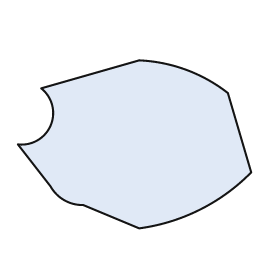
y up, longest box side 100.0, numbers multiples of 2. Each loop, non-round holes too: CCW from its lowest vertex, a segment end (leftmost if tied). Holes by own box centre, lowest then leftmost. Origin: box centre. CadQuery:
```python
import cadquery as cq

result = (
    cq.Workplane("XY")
    .moveTo(2.0, -36.0)
    .threePointArc((28.0, -28.0), (50.0, -12.0))
    .lineTo(40.0, 22.0)
    .threePointArc((22.0, 32.0), (2.0, 36.0))
    .lineTo(-40.0, 24.0)
    .threePointArc((-36.0, 8.0), (-50.0, 0.0))
    .lineTo(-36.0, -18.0)
    .threePointArc((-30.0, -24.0), (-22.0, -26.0))
    .close()
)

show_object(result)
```